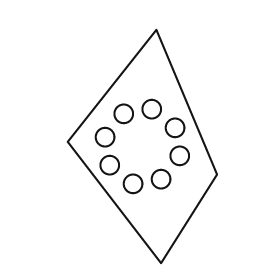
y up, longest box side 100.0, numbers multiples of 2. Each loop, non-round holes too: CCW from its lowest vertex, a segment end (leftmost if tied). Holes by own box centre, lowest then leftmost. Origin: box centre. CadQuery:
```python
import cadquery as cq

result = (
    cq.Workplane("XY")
    .moveTo(8.0, -50.0)
    .lineTo(32.0, -12.0)
    .lineTo(6.0, 50.0)
    .lineTo(-32.0, 2.0)
    .close()
    .moveTo(-4.0, -16.0)
    .circle(4.0)
    .moveTo(8.0, -14.0)
    .circle(4.0)
    .moveTo(-14.0, -8.0)
    .circle(4.0)
    .moveTo(16.0, -4.0)
    .circle(4.0)
    .moveTo(-16.0, 4.0)
    .circle(4.0)
    .moveTo(14.0, 8.0)
    .circle(4.0)
    .moveTo(-8.0, 14.0)
    .circle(4.0)
    .moveTo(4.0, 16.0)
    .circle(4.0)
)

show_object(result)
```